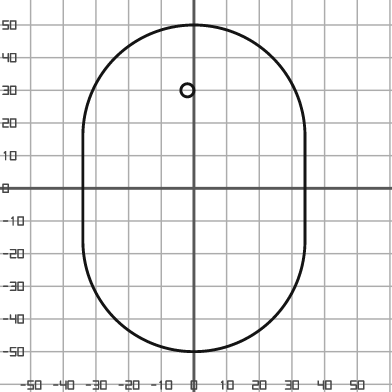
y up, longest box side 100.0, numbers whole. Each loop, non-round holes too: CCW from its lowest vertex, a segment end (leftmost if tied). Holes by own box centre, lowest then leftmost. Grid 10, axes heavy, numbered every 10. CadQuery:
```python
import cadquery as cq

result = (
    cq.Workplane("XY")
    .moveTo(-34.0, -16.0)
    .threePointArc((0.0, -50.0), (34.0, -16.0))
    .lineTo(34.0, 16.0)
    .threePointArc((0.0, 50.0), (-34.0, 16.0))
    .close()
    .moveTo(-2.0, 30.0)
    .circle(2.0)
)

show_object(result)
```